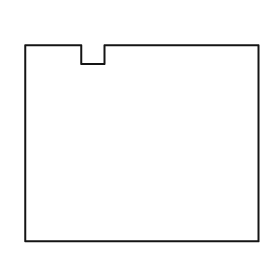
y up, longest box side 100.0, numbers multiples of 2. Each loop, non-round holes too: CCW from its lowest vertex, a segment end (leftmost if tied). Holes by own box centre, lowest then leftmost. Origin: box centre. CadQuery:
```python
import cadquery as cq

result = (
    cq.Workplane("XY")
    .moveTo(-50.0, -42.0)
    .lineTo(50.0, -42.0)
    .lineTo(50.0, 42.0)
    .lineTo(-16.0, 42.0)
    .lineTo(-16.0, 34.0)
    .lineTo(-26.0, 34.0)
    .lineTo(-26.0, 42.0)
    .lineTo(-50.0, 42.0)
    .close()
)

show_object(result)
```